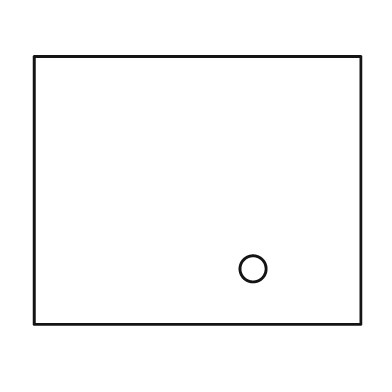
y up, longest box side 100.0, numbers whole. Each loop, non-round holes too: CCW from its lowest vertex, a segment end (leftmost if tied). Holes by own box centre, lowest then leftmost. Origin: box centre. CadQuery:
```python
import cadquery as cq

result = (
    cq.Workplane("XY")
    .moveTo(-50.0, -41.0)
    .lineTo(50.0, -41.0)
    .lineTo(50.0, 41.0)
    .lineTo(-50.0, 41.0)
    .close()
    .moveTo(17.0, -24.0)
    .circle(4.0)
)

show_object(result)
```